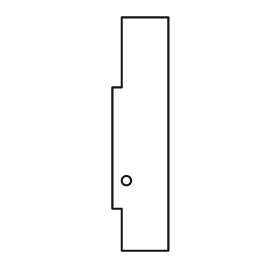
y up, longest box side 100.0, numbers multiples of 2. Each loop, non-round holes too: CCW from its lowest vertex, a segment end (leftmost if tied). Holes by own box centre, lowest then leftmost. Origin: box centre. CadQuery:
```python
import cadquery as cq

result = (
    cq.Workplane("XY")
    .moveTo(-8.0, -50.0)
    .lineTo(12.0, -50.0)
    .lineTo(12.0, 50.0)
    .lineTo(-8.0, 50.0)
    .lineTo(-8.0, 20.0)
    .lineTo(-12.0, 20.0)
    .lineTo(-12.0, -32.0)
    .lineTo(-8.0, -32.0)
    .close()
    .moveTo(-6.0, -20.0)
    .circle(2.0)
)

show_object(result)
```